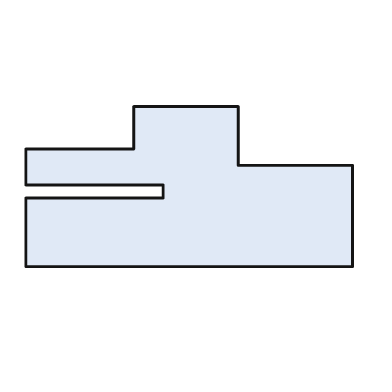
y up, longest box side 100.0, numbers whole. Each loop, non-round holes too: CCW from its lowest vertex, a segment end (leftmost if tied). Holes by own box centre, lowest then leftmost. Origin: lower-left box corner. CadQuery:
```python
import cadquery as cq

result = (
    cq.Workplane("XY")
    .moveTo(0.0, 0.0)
    .lineTo(100.0, 0.0)
    .lineTo(100.0, 31.0)
    .lineTo(65.0, 31.0)
    .lineTo(65.0, 49.0)
    .lineTo(33.0, 49.0)
    .lineTo(33.0, 36.0)
    .lineTo(0.0, 36.0)
    .lineTo(0.0, 25.0)
    .lineTo(42.0, 25.0)
    .lineTo(42.0, 21.0)
    .lineTo(0.0, 21.0)
    .close()
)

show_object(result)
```